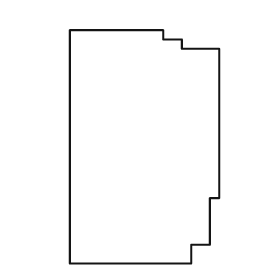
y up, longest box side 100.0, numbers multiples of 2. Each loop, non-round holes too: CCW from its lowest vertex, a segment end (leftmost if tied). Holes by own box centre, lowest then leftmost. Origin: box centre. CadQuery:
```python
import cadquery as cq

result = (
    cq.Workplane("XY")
    .moveTo(-32.0, -50.0)
    .lineTo(20.0, -50.0)
    .lineTo(20.0, -42.0)
    .lineTo(28.0, -42.0)
    .lineTo(28.0, -22.0)
    .lineTo(32.0, -22.0)
    .lineTo(32.0, 42.0)
    .lineTo(16.0, 42.0)
    .lineTo(16.0, 46.0)
    .lineTo(8.0, 46.0)
    .lineTo(8.0, 50.0)
    .lineTo(-32.0, 50.0)
    .close()
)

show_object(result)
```